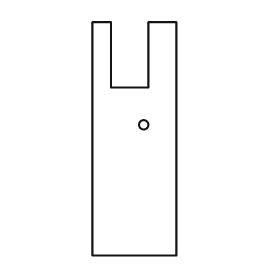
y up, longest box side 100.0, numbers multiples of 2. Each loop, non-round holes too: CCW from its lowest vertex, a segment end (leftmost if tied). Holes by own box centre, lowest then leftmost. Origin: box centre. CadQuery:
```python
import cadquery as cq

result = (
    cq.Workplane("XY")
    .moveTo(-18.0, -50.0)
    .lineTo(18.0, -50.0)
    .lineTo(18.0, 50.0)
    .lineTo(6.0, 50.0)
    .lineTo(6.0, 22.0)
    .lineTo(-10.0, 22.0)
    .lineTo(-10.0, 50.0)
    .lineTo(-18.0, 50.0)
    .close()
    .moveTo(4.0, 6.0)
    .circle(2.0)
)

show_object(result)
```